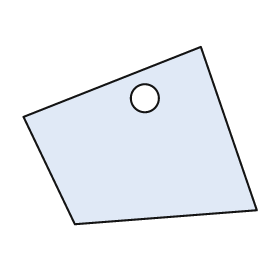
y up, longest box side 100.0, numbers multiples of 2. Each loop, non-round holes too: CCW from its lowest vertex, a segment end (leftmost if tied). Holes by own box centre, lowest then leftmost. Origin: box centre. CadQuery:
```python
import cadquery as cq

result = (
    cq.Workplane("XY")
    .moveTo(-28.0, -38.0)
    .lineTo(50.0, -32.0)
    .lineTo(26.0, 38.0)
    .lineTo(-50.0, 8.0)
    .close()
    .moveTo(2.0, 16.0)
    .circle(6.0)
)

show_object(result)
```